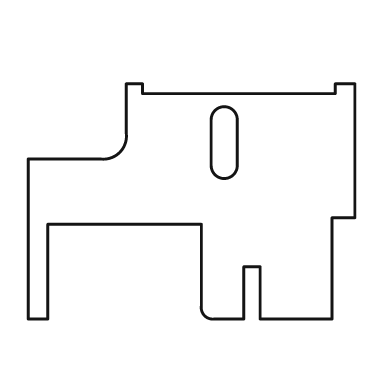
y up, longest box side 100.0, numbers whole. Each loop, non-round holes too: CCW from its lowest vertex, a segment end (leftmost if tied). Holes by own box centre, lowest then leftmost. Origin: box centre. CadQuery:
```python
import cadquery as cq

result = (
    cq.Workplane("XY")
    .moveTo(-50.0, -36.0)
    .lineTo(-44.0, -36.0)
    .lineTo(-44.0, -7.0)
    .lineTo(3.0, -7.0)
    .lineTo(3.0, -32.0)
    .threePointArc((4.0, -35.0), (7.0, -36.0))
    .lineTo(16.0, -36.0)
    .lineTo(16.0, -20.0)
    .lineTo(21.0, -20.0)
    .lineTo(21.0, -36.0)
    .lineTo(43.0, -36.0)
    .lineTo(43.0, -5.0)
    .lineTo(50.0, -5.0)
    .lineTo(50.0, 36.0)
    .lineTo(44.0, 36.0)
    .lineTo(44.0, 33.0)
    .lineTo(-15.0, 33.0)
    .lineTo(-15.0, 36.0)
    .lineTo(-20.0, 36.0)
    .lineTo(-20.0, 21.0)
    .threePointArc((-22.0, 15.0), (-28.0, 13.0))
    .lineTo(-50.0, 13.0)
    .close()
    .moveTo(6.0, 11.0)
    .threePointArc((10.0, 7.0), (14.0, 11.0))
    .lineTo(14.0, 25.0)
    .threePointArc((10.0, 29.0), (6.0, 25.0))
    .close()
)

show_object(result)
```